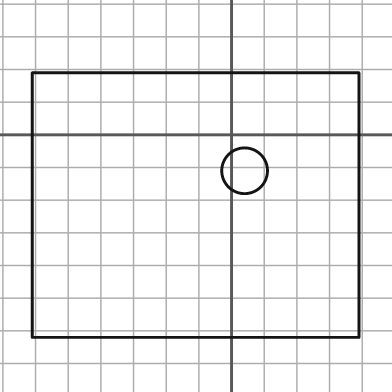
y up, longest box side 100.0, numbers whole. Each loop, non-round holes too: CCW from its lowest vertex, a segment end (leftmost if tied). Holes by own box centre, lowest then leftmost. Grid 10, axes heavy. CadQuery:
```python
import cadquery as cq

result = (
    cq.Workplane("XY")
    .moveTo(-61.0, -62.0)
    .lineTo(39.0, -62.0)
    .lineTo(39.0, 19.0)
    .lineTo(-61.0, 19.0)
    .close()
    .moveTo(4.0, -11.0)
    .circle(7.0)
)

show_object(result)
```